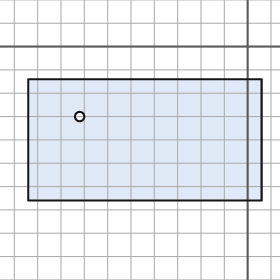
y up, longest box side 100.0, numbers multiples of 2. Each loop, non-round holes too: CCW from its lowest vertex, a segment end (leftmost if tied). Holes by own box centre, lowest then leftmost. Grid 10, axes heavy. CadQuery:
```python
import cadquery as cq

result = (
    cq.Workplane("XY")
    .moveTo(-94.0, -66.0)
    .lineTo(6.0, -66.0)
    .lineTo(6.0, -14.0)
    .lineTo(-94.0, -14.0)
    .close()
    .moveTo(-72.0, -30.0)
    .circle(2.0)
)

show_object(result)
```